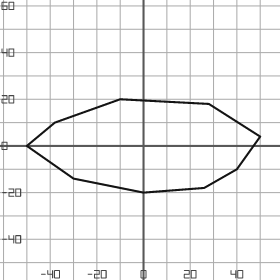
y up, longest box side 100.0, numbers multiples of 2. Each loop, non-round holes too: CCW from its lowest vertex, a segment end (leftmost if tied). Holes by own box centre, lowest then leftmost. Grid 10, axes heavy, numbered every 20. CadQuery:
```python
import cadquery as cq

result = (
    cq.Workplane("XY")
    .moveTo(0.0, -20.0)
    .lineTo(26.0, -18.0)
    .lineTo(40.0, -10.0)
    .lineTo(50.0, 4.0)
    .lineTo(28.0, 18.0)
    .lineTo(-10.0, 20.0)
    .lineTo(-38.0, 10.0)
    .lineTo(-50.0, 0.0)
    .lineTo(-30.0, -14.0)
    .close()
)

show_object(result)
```